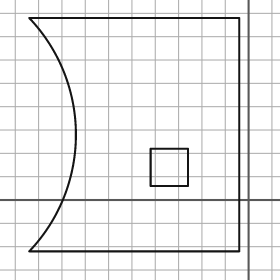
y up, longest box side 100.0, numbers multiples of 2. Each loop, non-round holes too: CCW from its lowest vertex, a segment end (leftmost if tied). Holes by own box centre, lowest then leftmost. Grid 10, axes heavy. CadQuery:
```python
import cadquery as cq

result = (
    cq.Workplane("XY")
    .moveTo(-94.0, -22.0)
    .lineTo(-4.0, -22.0)
    .lineTo(-4.0, 78.0)
    .lineTo(-94.0, 78.0)
    .threePointArc((-74.0, 28.0), (-94.0, -22.0))
    .close()
    .moveTo(-42.0, 6.0)
    .lineTo(-26.0, 6.0)
    .lineTo(-26.0, 22.0)
    .lineTo(-42.0, 22.0)
    .close()
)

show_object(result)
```